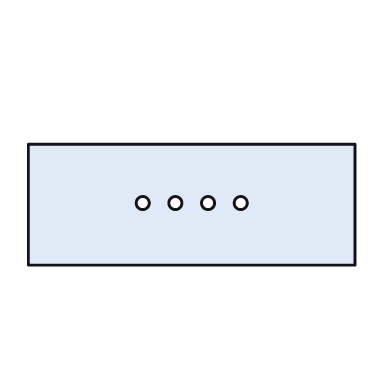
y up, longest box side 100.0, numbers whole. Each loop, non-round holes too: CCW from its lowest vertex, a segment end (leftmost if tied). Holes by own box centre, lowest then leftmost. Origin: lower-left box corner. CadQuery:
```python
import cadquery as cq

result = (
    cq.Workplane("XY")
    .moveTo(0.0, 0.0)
    .lineTo(100.0, 0.0)
    .lineTo(100.0, 37.0)
    .lineTo(0.0, 37.0)
    .close()
    .moveTo(35.0, 19.0)
    .circle(2.0)
    .moveTo(45.0, 19.0)
    .circle(2.0)
    .moveTo(55.0, 19.0)
    .circle(2.0)
    .moveTo(65.0, 19.0)
    .circle(2.0)
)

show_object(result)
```